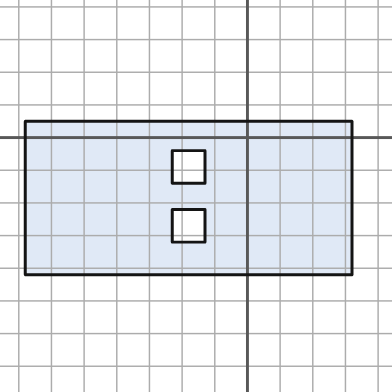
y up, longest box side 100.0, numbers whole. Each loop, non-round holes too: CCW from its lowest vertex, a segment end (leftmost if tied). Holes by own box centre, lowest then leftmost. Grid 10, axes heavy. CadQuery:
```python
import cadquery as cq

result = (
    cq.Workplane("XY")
    .moveTo(-68.0, -42.0)
    .lineTo(32.0, -42.0)
    .lineTo(32.0, 5.0)
    .lineTo(-68.0, 5.0)
    .close()
    .moveTo(-23.0, -32.0)
    .lineTo(-13.0, -32.0)
    .lineTo(-13.0, -22.0)
    .lineTo(-23.0, -22.0)
    .close()
    .moveTo(-23.0, -14.0)
    .lineTo(-13.0, -14.0)
    .lineTo(-13.0, -4.0)
    .lineTo(-23.0, -4.0)
    .close()
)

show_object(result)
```